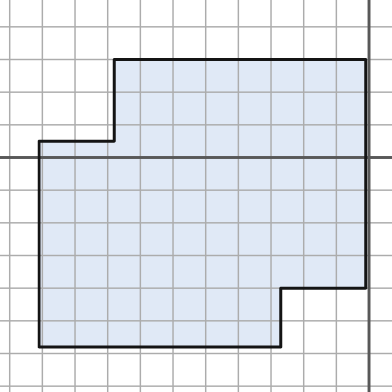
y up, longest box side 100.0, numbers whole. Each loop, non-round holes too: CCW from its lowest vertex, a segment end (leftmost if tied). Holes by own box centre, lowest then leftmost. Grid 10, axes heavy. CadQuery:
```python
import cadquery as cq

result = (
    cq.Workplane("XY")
    .moveTo(-101.0, -58.0)
    .lineTo(-27.0, -58.0)
    .lineTo(-27.0, -40.0)
    .lineTo(-1.0, -40.0)
    .lineTo(-1.0, 30.0)
    .lineTo(-78.0, 30.0)
    .lineTo(-78.0, 5.0)
    .lineTo(-101.0, 5.0)
    .close()
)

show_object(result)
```